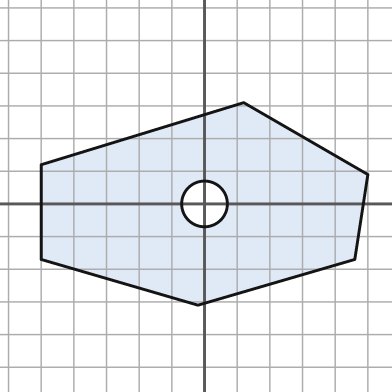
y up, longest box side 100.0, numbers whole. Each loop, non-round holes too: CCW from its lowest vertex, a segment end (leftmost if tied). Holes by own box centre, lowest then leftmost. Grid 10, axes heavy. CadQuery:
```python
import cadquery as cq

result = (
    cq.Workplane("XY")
    .moveTo(-2.0, -31.0)
    .lineTo(46.0, -17.0)
    .lineTo(50.0, 9.0)
    .lineTo(12.0, 31.0)
    .lineTo(-50.0, 12.0)
    .lineTo(-50.0, -17.0)
    .close()
    .moveTo(0.0, 0.0)
    .circle(7.0)
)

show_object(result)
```